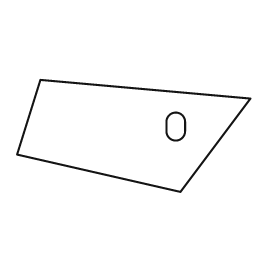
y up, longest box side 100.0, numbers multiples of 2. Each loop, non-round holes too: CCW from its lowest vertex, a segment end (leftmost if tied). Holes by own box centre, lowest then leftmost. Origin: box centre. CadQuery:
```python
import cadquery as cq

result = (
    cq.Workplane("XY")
    .moveTo(20.0, -24.0)
    .lineTo(50.0, 16.0)
    .lineTo(-40.0, 24.0)
    .lineTo(-50.0, -8.0)
    .close()
    .moveTo(14.0, 2.0)
    .threePointArc((18.0, -2.0), (22.0, 2.0))
    .lineTo(22.0, 6.0)
    .threePointArc((18.0, 10.0), (14.0, 6.0))
    .close()
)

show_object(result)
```